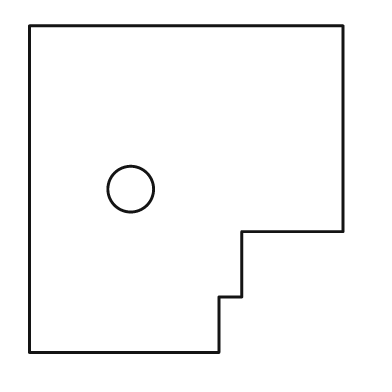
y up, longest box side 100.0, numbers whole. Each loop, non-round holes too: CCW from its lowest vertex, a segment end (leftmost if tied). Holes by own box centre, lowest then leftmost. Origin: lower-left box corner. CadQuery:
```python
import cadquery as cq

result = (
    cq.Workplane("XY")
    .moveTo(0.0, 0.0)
    .lineTo(58.0, 0.0)
    .lineTo(58.0, 17.0)
    .lineTo(65.0, 17.0)
    .lineTo(65.0, 37.0)
    .lineTo(96.0, 37.0)
    .lineTo(96.0, 100.0)
    .lineTo(0.0, 100.0)
    .close()
    .moveTo(31.0, 50.0)
    .circle(7.0)
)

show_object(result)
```